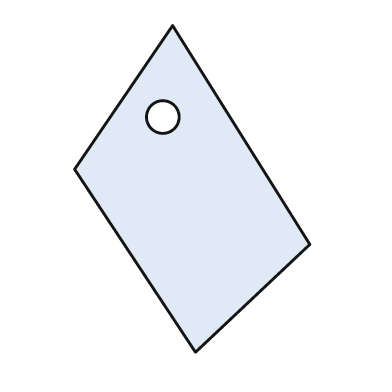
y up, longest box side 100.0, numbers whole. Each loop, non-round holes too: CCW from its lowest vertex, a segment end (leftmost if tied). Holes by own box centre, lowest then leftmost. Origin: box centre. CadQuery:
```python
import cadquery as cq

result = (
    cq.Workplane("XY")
    .moveTo(1.0, -50.0)
    .lineTo(36.0, -17.0)
    .lineTo(-6.0, 50.0)
    .lineTo(-36.0, 6.0)
    .close()
    .moveTo(-9.0, 22.0)
    .circle(5.0)
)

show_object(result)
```